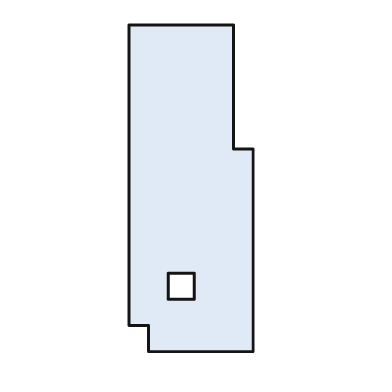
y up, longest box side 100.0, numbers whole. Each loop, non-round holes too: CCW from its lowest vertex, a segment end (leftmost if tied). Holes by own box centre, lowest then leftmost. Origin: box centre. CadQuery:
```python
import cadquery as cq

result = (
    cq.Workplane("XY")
    .moveTo(-13.0, -50.0)
    .lineTo(19.0, -50.0)
    .lineTo(19.0, 12.0)
    .lineTo(13.0, 12.0)
    .lineTo(13.0, 50.0)
    .lineTo(-19.0, 50.0)
    .lineTo(-19.0, -42.0)
    .lineTo(-13.0, -42.0)
    .close()
    .moveTo(-7.0, -34.0)
    .lineTo(1.0, -34.0)
    .lineTo(1.0, -26.0)
    .lineTo(-7.0, -26.0)
    .close()
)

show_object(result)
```